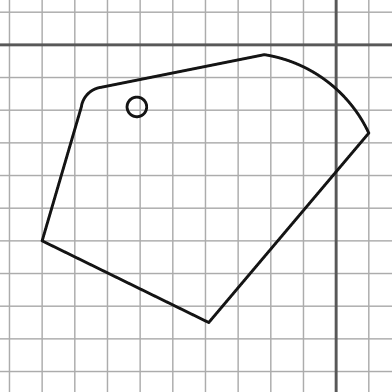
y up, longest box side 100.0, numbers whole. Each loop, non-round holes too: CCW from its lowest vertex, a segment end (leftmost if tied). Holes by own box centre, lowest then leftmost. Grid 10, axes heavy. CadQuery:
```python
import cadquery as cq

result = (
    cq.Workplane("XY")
    .moveTo(-39.0, -85.0)
    .lineTo(10.0, -27.0)
    .threePointArc((-3.0, -11.0), (-22.0, -3.0))
    .lineTo(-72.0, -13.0)
    .threePointArc((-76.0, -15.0), (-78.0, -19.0))
    .lineTo(-90.0, -60.0)
    .close()
    .moveTo(-61.0, -19.0)
    .circle(3.0)
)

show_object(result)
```